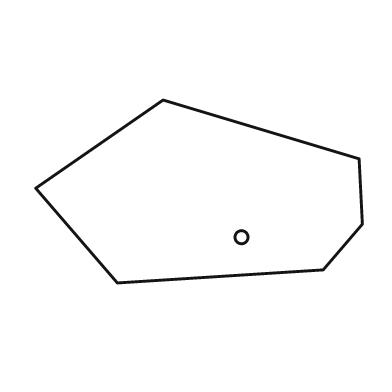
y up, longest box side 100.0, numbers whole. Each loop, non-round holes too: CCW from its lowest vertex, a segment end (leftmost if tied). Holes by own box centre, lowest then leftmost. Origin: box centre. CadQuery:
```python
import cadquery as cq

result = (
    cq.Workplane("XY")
    .moveTo(-25.0, -28.0)
    .lineTo(38.0, -24.0)
    .lineTo(50.0, -10.0)
    .lineTo(49.0, 10.0)
    .lineTo(-11.0, 28.0)
    .lineTo(-50.0, 1.0)
    .close()
    .moveTo(13.0, -14.0)
    .circle(2.0)
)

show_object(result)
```